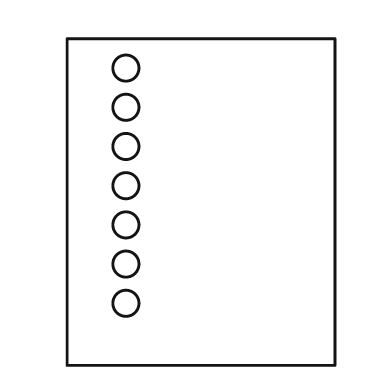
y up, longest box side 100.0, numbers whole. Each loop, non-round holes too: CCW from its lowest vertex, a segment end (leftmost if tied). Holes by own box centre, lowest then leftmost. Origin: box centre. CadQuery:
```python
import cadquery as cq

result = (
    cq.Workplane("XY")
    .moveTo(-41.0, -50.0)
    .lineTo(41.0, -50.0)
    .lineTo(41.0, 50.0)
    .lineTo(-41.0, 50.0)
    .close()
    .moveTo(-23.0, -31.0)
    .circle(4.0)
    .moveTo(-23.0, -19.0)
    .circle(4.0)
    .moveTo(-23.0, -7.0)
    .circle(4.0)
    .moveTo(-23.0, 5.0)
    .circle(4.0)
    .moveTo(-23.0, 17.0)
    .circle(4.0)
    .moveTo(-23.0, 29.0)
    .circle(4.0)
    .moveTo(-23.0, 41.0)
    .circle(4.0)
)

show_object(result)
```